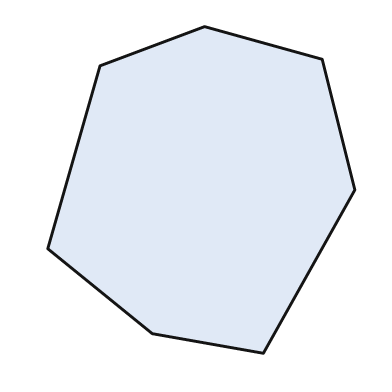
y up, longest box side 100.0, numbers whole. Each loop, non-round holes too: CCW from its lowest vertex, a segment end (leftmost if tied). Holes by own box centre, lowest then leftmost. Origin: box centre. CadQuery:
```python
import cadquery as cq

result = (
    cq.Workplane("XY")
    .moveTo(19.0, -50.0)
    .lineTo(47.0, 0.0)
    .lineTo(37.0, 40.0)
    .lineTo(1.0, 50.0)
    .lineTo(-31.0, 38.0)
    .lineTo(-47.0, -18.0)
    .lineTo(-15.0, -44.0)
    .close()
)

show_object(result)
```